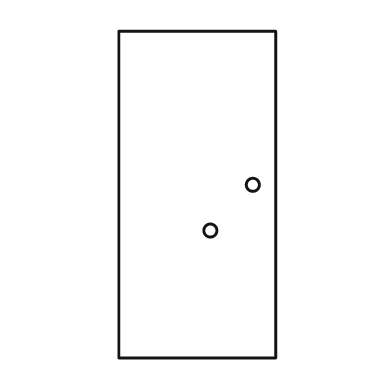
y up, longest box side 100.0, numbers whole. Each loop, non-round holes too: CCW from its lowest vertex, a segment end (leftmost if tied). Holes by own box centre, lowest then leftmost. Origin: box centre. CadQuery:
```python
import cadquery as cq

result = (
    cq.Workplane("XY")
    .moveTo(-24.0, -50.0)
    .lineTo(24.0, -50.0)
    .lineTo(24.0, 50.0)
    .lineTo(-24.0, 50.0)
    .close()
    .moveTo(4.0, -11.0)
    .circle(2.0)
    .moveTo(17.0, 3.0)
    .circle(2.0)
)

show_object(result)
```